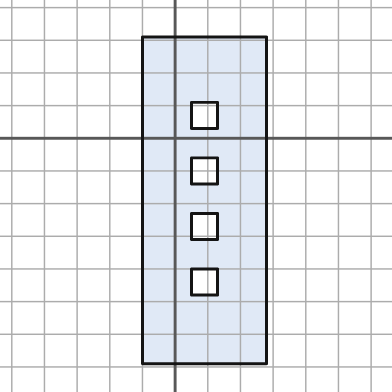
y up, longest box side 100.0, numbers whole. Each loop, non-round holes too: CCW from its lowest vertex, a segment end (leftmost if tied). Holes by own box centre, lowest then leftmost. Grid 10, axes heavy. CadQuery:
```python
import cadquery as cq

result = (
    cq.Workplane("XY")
    .moveTo(-10.0, -69.0)
    .lineTo(28.0, -69.0)
    .lineTo(28.0, 31.0)
    .lineTo(-10.0, 31.0)
    .close()
    .moveTo(5.0, -48.0)
    .lineTo(13.0, -48.0)
    .lineTo(13.0, -40.0)
    .lineTo(5.0, -40.0)
    .close()
    .moveTo(5.0, -31.0)
    .lineTo(13.0, -31.0)
    .lineTo(13.0, -23.0)
    .lineTo(5.0, -23.0)
    .close()
    .moveTo(5.0, -14.0)
    .lineTo(13.0, -14.0)
    .lineTo(13.0, -6.0)
    .lineTo(5.0, -6.0)
    .close()
    .moveTo(5.0, 3.0)
    .lineTo(13.0, 3.0)
    .lineTo(13.0, 11.0)
    .lineTo(5.0, 11.0)
    .close()
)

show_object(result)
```